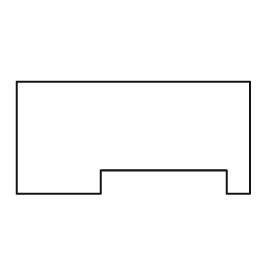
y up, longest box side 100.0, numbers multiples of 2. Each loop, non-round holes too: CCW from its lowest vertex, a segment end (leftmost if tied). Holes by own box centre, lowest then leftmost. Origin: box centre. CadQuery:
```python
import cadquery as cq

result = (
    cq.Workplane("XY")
    .moveTo(-50.0, -24.0)
    .lineTo(-14.0, -24.0)
    .lineTo(-14.0, -14.0)
    .lineTo(40.0, -14.0)
    .lineTo(40.0, -24.0)
    .lineTo(50.0, -24.0)
    .lineTo(50.0, 24.0)
    .lineTo(-50.0, 24.0)
    .close()
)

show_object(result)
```